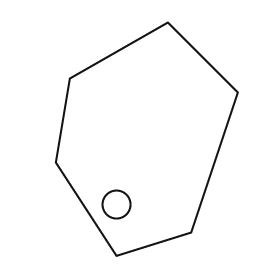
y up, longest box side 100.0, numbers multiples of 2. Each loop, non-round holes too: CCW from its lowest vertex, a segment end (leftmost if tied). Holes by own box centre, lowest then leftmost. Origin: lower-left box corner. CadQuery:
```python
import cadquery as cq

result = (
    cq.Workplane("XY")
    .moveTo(26.0, 0.0)
    .lineTo(58.0, 10.0)
    .lineTo(78.0, 70.0)
    .lineTo(48.0, 100.0)
    .lineTo(6.0, 76.0)
    .lineTo(0.0, 40.0)
    .close()
    .moveTo(26.0, 22.0)
    .circle(6.0)
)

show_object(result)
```